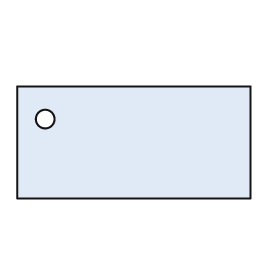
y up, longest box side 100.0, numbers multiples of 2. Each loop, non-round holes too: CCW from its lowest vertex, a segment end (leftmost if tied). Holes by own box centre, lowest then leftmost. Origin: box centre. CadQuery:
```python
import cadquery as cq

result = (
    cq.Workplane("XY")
    .moveTo(-50.0, -24.0)
    .lineTo(50.0, -24.0)
    .lineTo(50.0, 24.0)
    .lineTo(-50.0, 24.0)
    .close()
    .moveTo(-38.0, 10.0)
    .circle(4.0)
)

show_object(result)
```